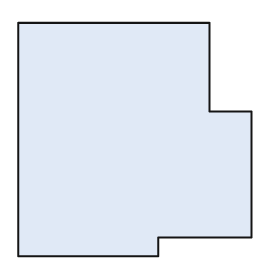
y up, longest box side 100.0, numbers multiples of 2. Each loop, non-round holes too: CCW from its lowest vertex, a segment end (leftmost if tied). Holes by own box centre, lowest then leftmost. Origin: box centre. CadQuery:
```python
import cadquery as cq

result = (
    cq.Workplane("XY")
    .moveTo(-50.0, -50.0)
    .lineTo(10.0, -50.0)
    .lineTo(10.0, -42.0)
    .lineTo(50.0, -42.0)
    .lineTo(50.0, 12.0)
    .lineTo(32.0, 12.0)
    .lineTo(32.0, 50.0)
    .lineTo(-50.0, 50.0)
    .close()
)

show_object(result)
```